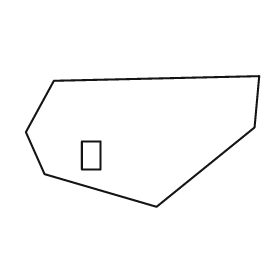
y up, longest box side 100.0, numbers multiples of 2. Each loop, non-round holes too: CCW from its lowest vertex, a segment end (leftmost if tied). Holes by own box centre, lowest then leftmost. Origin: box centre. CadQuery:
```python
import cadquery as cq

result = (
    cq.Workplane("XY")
    .moveTo(6.0, -28.0)
    .lineTo(48.0, 6.0)
    .lineTo(50.0, 28.0)
    .lineTo(-38.0, 26.0)
    .lineTo(-50.0, 4.0)
    .lineTo(-42.0, -14.0)
    .close()
    .moveTo(-26.0, -12.0)
    .lineTo(-18.0, -12.0)
    .lineTo(-18.0, 0.0)
    .lineTo(-26.0, 0.0)
    .close()
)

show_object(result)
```